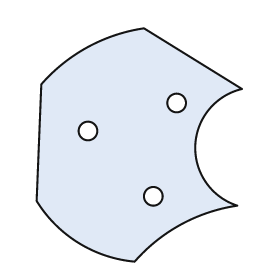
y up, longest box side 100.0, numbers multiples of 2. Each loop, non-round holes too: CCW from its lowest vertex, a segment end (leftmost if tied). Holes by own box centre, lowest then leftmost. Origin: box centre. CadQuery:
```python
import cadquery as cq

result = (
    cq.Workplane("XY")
    .moveTo(-2.0, -50.0)
    .threePointArc((18.0, -34.0), (42.0, -26.0))
    .threePointArc((24.0, 0.0), (44.0, 24.0))
    .lineTo(2.0, 50.0)
    .threePointArc((-22.0, 42.0), (-42.0, 26.0))
    .lineTo(-44.0, -24.0)
    .threePointArc((-26.0, -42.0), (-2.0, -50.0))
    .close()
    .moveTo(6.0, -22.0)
    .circle(4.0)
    .moveTo(-22.0, 6.0)
    .circle(4.0)
    .moveTo(16.0, 18.0)
    .circle(4.0)
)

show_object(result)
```